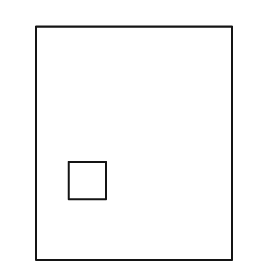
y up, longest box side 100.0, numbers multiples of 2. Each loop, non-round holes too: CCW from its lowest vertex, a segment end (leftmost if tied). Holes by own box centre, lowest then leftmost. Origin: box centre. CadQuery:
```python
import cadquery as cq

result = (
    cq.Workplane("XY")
    .moveTo(-42.0, -50.0)
    .lineTo(42.0, -50.0)
    .lineTo(42.0, 50.0)
    .lineTo(-42.0, 50.0)
    .close()
    .moveTo(-28.0, -24.0)
    .lineTo(-12.0, -24.0)
    .lineTo(-12.0, -8.0)
    .lineTo(-28.0, -8.0)
    .close()
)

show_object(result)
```